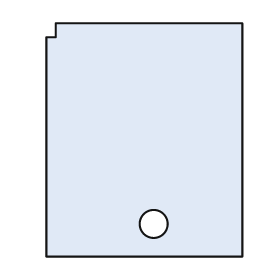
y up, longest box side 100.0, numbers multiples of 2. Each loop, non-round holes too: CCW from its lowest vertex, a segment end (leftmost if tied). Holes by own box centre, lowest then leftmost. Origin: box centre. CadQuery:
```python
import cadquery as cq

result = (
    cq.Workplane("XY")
    .moveTo(-42.0, -50.0)
    .lineTo(42.0, -50.0)
    .lineTo(42.0, 50.0)
    .lineTo(-38.0, 50.0)
    .lineTo(-38.0, 44.0)
    .lineTo(-42.0, 44.0)
    .close()
    .moveTo(4.0, -36.0)
    .circle(6.0)
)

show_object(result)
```